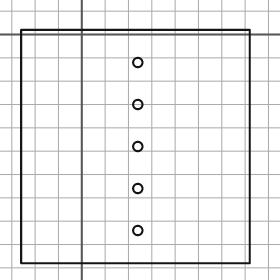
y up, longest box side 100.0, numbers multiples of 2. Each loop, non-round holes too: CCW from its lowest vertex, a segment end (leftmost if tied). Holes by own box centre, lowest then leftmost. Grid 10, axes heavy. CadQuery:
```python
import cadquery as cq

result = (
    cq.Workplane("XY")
    .moveTo(-26.0, -98.0)
    .lineTo(72.0, -98.0)
    .lineTo(72.0, 2.0)
    .lineTo(-26.0, 2.0)
    .close()
    .moveTo(24.0, -84.0)
    .circle(2.0)
    .moveTo(24.0, -66.0)
    .circle(2.0)
    .moveTo(24.0, -48.0)
    .circle(2.0)
    .moveTo(24.0, -30.0)
    .circle(2.0)
    .moveTo(24.0, -12.0)
    .circle(2.0)
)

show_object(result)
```